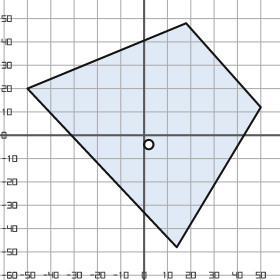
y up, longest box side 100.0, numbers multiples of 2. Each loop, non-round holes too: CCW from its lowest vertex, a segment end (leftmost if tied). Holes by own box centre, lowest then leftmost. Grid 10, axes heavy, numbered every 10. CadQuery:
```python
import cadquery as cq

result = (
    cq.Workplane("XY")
    .moveTo(14.0, -48.0)
    .lineTo(50.0, 12.0)
    .lineTo(18.0, 48.0)
    .lineTo(-50.0, 20.0)
    .close()
    .moveTo(2.0, -4.0)
    .circle(2.0)
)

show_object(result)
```